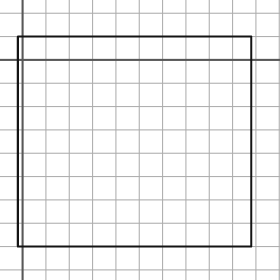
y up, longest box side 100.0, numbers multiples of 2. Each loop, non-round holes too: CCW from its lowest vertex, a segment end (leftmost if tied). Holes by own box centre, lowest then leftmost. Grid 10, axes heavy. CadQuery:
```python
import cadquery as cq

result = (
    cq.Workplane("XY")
    .moveTo(-2.0, -80.0)
    .lineTo(98.0, -80.0)
    .lineTo(98.0, 10.0)
    .lineTo(-2.0, 10.0)
    .close()
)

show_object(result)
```